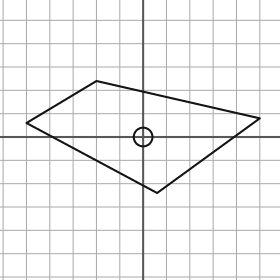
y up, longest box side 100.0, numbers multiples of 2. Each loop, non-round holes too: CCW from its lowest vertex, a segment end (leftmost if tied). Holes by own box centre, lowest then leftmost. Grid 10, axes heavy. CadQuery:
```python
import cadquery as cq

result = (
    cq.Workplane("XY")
    .moveTo(6.0, -24.0)
    .lineTo(50.0, 8.0)
    .lineTo(-20.0, 24.0)
    .lineTo(-50.0, 6.0)
    .close()
    .moveTo(0.0, 0.0)
    .circle(4.0)
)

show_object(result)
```